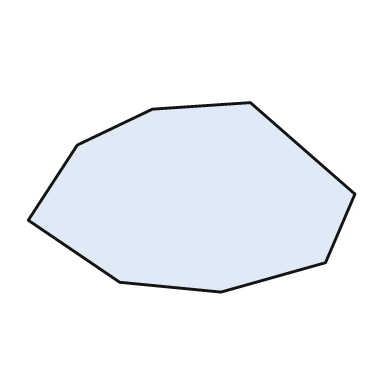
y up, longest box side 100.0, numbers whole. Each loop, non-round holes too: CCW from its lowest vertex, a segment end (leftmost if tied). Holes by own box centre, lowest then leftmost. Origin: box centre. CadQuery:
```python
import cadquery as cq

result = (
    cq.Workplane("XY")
    .moveTo(9.0, -29.0)
    .lineTo(41.0, -20.0)
    .lineTo(50.0, 1.0)
    .lineTo(18.0, 29.0)
    .lineTo(-12.0, 27.0)
    .lineTo(-35.0, 16.0)
    .lineTo(-50.0, -7.0)
    .lineTo(-22.0, -26.0)
    .close()
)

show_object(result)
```